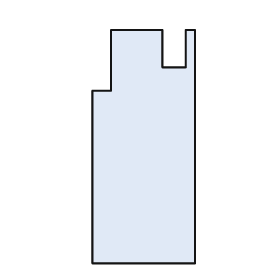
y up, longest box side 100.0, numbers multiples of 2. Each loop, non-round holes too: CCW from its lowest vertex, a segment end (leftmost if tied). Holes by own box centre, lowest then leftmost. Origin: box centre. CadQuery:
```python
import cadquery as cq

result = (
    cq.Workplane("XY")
    .moveTo(-22.0, -50.0)
    .lineTo(22.0, -50.0)
    .lineTo(22.0, 50.0)
    .lineTo(18.0, 50.0)
    .lineTo(18.0, 34.0)
    .lineTo(8.0, 34.0)
    .lineTo(8.0, 50.0)
    .lineTo(-14.0, 50.0)
    .lineTo(-14.0, 24.0)
    .lineTo(-22.0, 24.0)
    .close()
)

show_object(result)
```